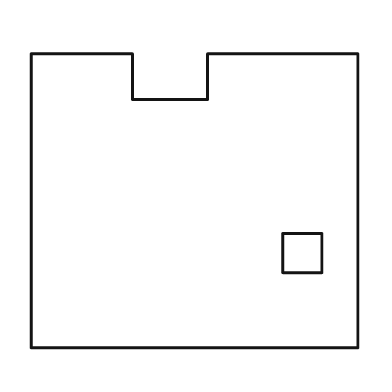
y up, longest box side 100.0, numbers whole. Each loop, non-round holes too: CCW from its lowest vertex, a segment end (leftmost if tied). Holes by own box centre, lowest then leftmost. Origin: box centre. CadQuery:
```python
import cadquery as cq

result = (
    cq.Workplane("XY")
    .moveTo(-50.0, -45.0)
    .lineTo(50.0, -45.0)
    .lineTo(50.0, 45.0)
    .lineTo(4.0, 45.0)
    .lineTo(4.0, 31.0)
    .lineTo(-19.0, 31.0)
    .lineTo(-19.0, 45.0)
    .lineTo(-50.0, 45.0)
    .close()
    .moveTo(27.0, -22.0)
    .lineTo(39.0, -22.0)
    .lineTo(39.0, -10.0)
    .lineTo(27.0, -10.0)
    .close()
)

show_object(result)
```